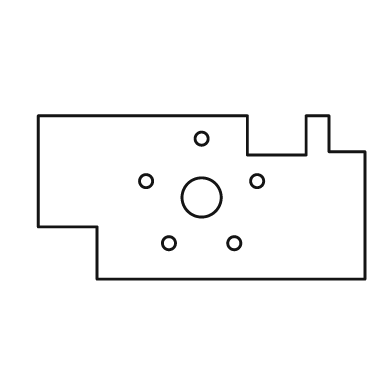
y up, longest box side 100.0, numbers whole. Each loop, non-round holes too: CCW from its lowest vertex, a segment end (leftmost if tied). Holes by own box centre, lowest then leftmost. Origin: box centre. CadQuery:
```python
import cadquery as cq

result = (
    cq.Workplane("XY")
    .moveTo(-32.0, -25.0)
    .lineTo(50.0, -25.0)
    .lineTo(50.0, 14.0)
    .lineTo(39.0, 14.0)
    .lineTo(39.0, 25.0)
    .lineTo(32.0, 25.0)
    .lineTo(32.0, 13.0)
    .lineTo(14.0, 13.0)
    .lineTo(14.0, 25.0)
    .lineTo(-50.0, 25.0)
    .lineTo(-50.0, -9.0)
    .lineTo(-32.0, -9.0)
    .close()
    .moveTo(-10.0, -14.0)
    .circle(2.0)
    .moveTo(10.0, -14.0)
    .circle(2.0)
    .moveTo(0.0, 0.0)
    .circle(6.0)
    .moveTo(-17.0, 5.0)
    .circle(2.0)
    .moveTo(17.0, 5.0)
    .circle(2.0)
    .moveTo(0.0, 18.0)
    .circle(2.0)
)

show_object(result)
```